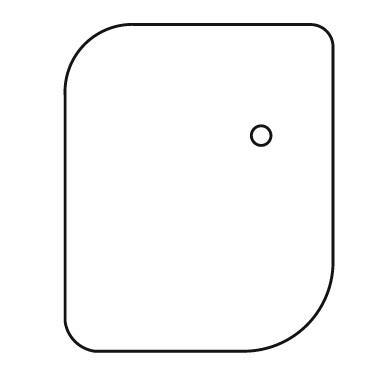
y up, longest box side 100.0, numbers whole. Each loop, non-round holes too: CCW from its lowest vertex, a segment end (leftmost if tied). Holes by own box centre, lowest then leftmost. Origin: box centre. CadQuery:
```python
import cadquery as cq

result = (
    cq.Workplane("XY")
    .moveTo(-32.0, -50.0)
    .lineTo(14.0, -50.0)
    .threePointArc((33.0, -42.0), (41.0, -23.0))
    .lineTo(41.0, 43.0)
    .threePointArc((39.0, 48.0), (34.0, 50.0))
    .lineTo(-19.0, 50.0)
    .threePointArc((-35.0, 44.0), (-41.0, 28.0))
    .lineTo(-41.0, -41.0)
    .threePointArc((-38.0, -47.0), (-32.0, -50.0))
    .close()
    .moveTo(19.0, 16.0)
    .circle(3.0)
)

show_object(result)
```